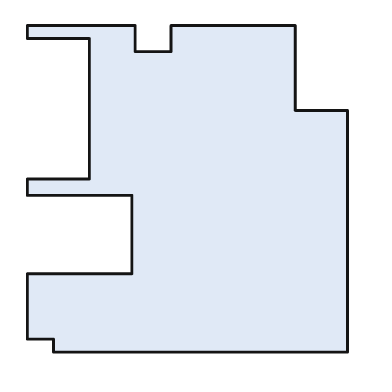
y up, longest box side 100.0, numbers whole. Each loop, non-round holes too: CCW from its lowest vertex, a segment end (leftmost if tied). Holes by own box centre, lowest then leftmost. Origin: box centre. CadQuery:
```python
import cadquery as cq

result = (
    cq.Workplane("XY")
    .moveTo(-41.0, -50.0)
    .lineTo(49.0, -50.0)
    .lineTo(49.0, 24.0)
    .lineTo(33.0, 24.0)
    .lineTo(33.0, 50.0)
    .lineTo(-5.0, 50.0)
    .lineTo(-5.0, 42.0)
    .lineTo(-16.0, 42.0)
    .lineTo(-16.0, 50.0)
    .lineTo(-49.0, 50.0)
    .lineTo(-49.0, 46.0)
    .lineTo(-30.0, 46.0)
    .lineTo(-30.0, 3.0)
    .lineTo(-49.0, 3.0)
    .lineTo(-49.0, -2.0)
    .lineTo(-17.0, -2.0)
    .lineTo(-17.0, -26.0)
    .lineTo(-49.0, -26.0)
    .lineTo(-49.0, -46.0)
    .lineTo(-41.0, -46.0)
    .close()
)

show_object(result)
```